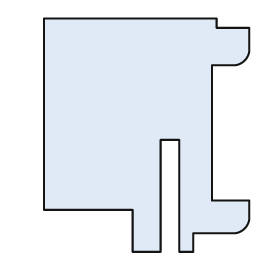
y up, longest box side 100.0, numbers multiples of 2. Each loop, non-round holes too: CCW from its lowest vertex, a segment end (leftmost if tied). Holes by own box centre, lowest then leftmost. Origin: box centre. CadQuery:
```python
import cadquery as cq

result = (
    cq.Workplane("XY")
    .moveTo(-6.0, -50.0)
    .lineTo(6.0, -50.0)
    .lineTo(6.0, -2.0)
    .lineTo(14.0, -2.0)
    .lineTo(14.0, -50.0)
    .lineTo(20.0, -50.0)
    .lineTo(20.0, -42.0)
    .lineTo(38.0, -42.0)
    .threePointArc((42.0, -40.0), (44.0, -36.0))
    .lineTo(44.0, -28.0)
    .lineTo(28.0, -28.0)
    .lineTo(28.0, 30.0)
    .lineTo(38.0, 30.0)
    .threePointArc((42.0, 32.0), (44.0, 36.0))
    .lineTo(44.0, 46.0)
    .lineTo(30.0, 46.0)
    .lineTo(30.0, 50.0)
    .lineTo(-44.0, 50.0)
    .lineTo(-44.0, -32.0)
    .lineTo(-6.0, -32.0)
    .close()
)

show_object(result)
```